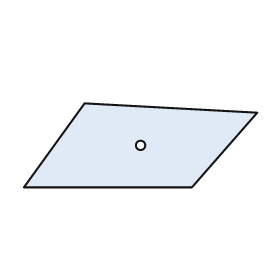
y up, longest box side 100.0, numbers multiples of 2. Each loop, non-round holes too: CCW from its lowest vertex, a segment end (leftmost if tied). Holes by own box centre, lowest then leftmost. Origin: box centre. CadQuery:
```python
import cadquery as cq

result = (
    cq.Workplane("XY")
    .moveTo(-50.0, -18.0)
    .lineTo(22.0, -18.0)
    .lineTo(50.0, 14.0)
    .lineTo(-24.0, 18.0)
    .close()
    .moveTo(0.0, 0.0)
    .circle(2.0)
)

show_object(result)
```